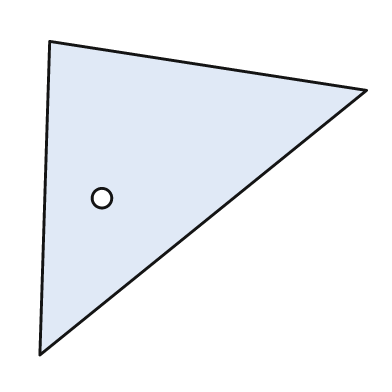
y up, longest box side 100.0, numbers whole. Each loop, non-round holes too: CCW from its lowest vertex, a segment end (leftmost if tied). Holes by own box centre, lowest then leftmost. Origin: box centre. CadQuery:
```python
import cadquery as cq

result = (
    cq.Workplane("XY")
    .moveTo(-50.0, -48.0)
    .lineTo(50.0, 33.0)
    .lineTo(-47.0, 48.0)
    .close()
    .moveTo(-31.0, 0.0)
    .circle(3.0)
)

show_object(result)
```